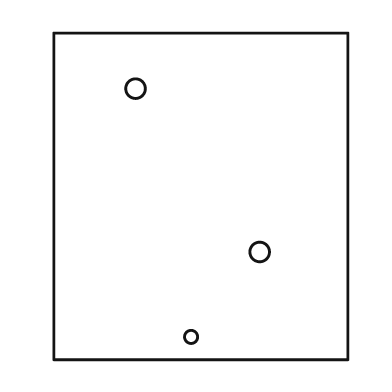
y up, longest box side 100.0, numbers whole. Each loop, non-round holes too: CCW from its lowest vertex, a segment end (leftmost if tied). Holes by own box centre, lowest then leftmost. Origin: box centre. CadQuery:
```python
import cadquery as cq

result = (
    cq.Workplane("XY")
    .moveTo(-45.0, -50.0)
    .lineTo(45.0, -50.0)
    .lineTo(45.0, 50.0)
    .lineTo(-45.0, 50.0)
    .close()
    .moveTo(-3.0, -43.0)
    .circle(2.0)
    .moveTo(18.0, -17.0)
    .circle(3.0)
    .moveTo(-20.0, 33.0)
    .circle(3.0)
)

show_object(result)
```